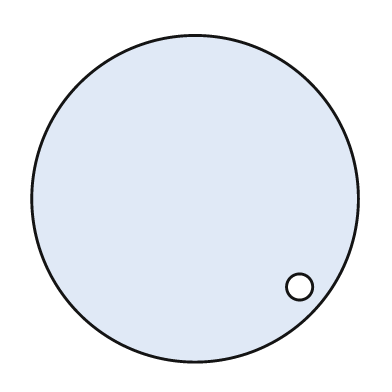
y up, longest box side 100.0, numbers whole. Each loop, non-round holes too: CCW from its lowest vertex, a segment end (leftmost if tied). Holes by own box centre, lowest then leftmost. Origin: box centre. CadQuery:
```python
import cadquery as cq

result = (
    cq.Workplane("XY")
    .moveTo(0.0, 0.0)
    .circle(50.0)
    .moveTo(32.0, -27.0)
    .circle(4.0)
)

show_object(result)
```